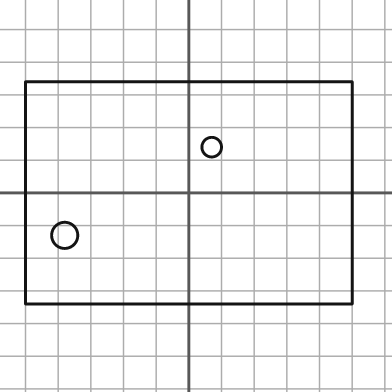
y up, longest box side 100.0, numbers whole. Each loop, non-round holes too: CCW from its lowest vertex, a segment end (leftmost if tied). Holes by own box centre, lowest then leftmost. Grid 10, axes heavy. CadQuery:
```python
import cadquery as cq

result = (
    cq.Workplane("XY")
    .moveTo(-50.0, -34.0)
    .lineTo(50.0, -34.0)
    .lineTo(50.0, 34.0)
    .lineTo(-50.0, 34.0)
    .close()
    .moveTo(-38.0, -13.0)
    .circle(4.0)
    .moveTo(7.0, 14.0)
    .circle(3.0)
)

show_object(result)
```